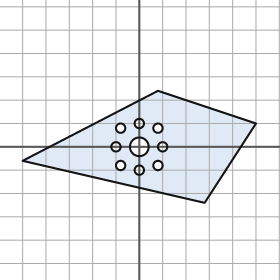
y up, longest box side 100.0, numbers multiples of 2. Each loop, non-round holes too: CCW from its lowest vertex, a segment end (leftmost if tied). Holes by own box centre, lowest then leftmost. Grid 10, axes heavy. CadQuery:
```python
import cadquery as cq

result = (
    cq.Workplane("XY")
    .moveTo(28.0, -24.0)
    .lineTo(50.0, 10.0)
    .lineTo(8.0, 24.0)
    .lineTo(-50.0, -6.0)
    .close()
    .moveTo(0.0, -10.0)
    .circle(2.0)
    .moveTo(-8.0, -8.0)
    .circle(2.0)
    .moveTo(8.0, -8.0)
    .circle(2.0)
    .moveTo(-10.0, 0.0)
    .circle(2.0)
    .moveTo(0.0, 0.0)
    .circle(4.0)
    .moveTo(10.0, 0.0)
    .circle(2.0)
    .moveTo(-8.0, 8.0)
    .circle(2.0)
    .moveTo(8.0, 8.0)
    .circle(2.0)
    .moveTo(0.0, 10.0)
    .circle(2.0)
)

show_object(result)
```